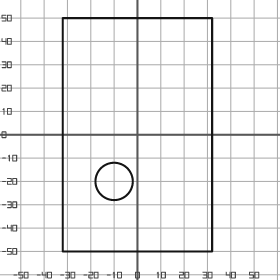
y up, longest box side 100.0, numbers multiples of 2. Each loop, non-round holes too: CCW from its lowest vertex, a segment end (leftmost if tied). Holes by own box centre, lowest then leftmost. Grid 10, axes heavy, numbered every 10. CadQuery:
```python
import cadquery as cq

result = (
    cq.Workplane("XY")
    .moveTo(-32.0, -50.0)
    .lineTo(32.0, -50.0)
    .lineTo(32.0, 50.0)
    .lineTo(-32.0, 50.0)
    .close()
    .moveTo(-10.0, -20.0)
    .circle(8.0)
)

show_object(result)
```